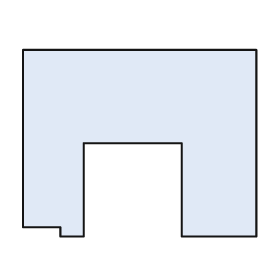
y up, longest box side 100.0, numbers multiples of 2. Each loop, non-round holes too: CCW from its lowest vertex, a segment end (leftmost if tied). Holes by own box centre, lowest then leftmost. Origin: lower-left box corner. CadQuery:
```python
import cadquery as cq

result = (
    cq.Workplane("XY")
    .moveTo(16.0, 0.0)
    .lineTo(26.0, 0.0)
    .lineTo(26.0, 40.0)
    .lineTo(68.0, 40.0)
    .lineTo(68.0, 0.0)
    .lineTo(100.0, 0.0)
    .lineTo(100.0, 80.0)
    .lineTo(0.0, 80.0)
    .lineTo(0.0, 4.0)
    .lineTo(16.0, 4.0)
    .close()
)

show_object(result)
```